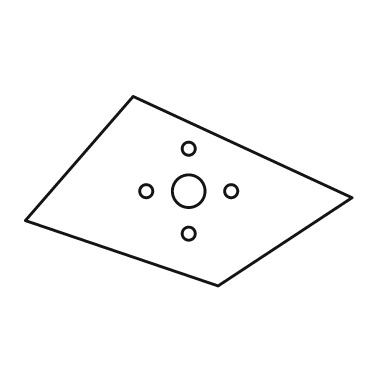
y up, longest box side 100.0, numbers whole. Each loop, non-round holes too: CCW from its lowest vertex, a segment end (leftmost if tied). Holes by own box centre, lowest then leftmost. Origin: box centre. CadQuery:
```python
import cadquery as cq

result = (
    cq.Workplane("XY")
    .moveTo(9.0, -29.0)
    .lineTo(50.0, -2.0)
    .lineTo(-17.0, 29.0)
    .lineTo(-50.0, -9.0)
    .close()
    .moveTo(0.0, -13.0)
    .circle(2.0)
    .moveTo(-13.0, 0.0)
    .circle(2.0)
    .moveTo(0.0, 0.0)
    .circle(5.0)
    .moveTo(13.0, 0.0)
    .circle(2.0)
    .moveTo(0.0, 13.0)
    .circle(2.0)
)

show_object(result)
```